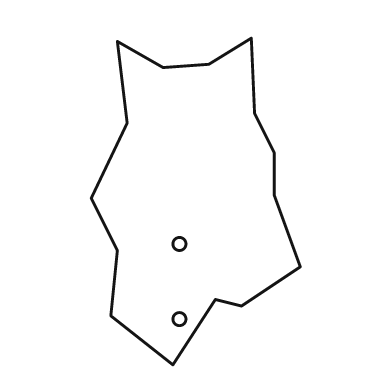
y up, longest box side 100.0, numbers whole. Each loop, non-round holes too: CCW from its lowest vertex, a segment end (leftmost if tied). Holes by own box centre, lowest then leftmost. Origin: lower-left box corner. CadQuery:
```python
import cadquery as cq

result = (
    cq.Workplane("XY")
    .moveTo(25.0, 0.0)
    .lineTo(38.0, 20.0)
    .lineTo(46.0, 18.0)
    .lineTo(64.0, 30.0)
    .lineTo(56.0, 52.0)
    .lineTo(56.0, 65.0)
    .lineTo(50.0, 77.0)
    .lineTo(49.0, 100.0)
    .lineTo(36.0, 92.0)
    .lineTo(22.0, 91.0)
    .lineTo(8.0, 99.0)
    .lineTo(11.0, 74.0)
    .lineTo(0.0, 51.0)
    .lineTo(8.0, 35.0)
    .lineTo(6.0, 15.0)
    .close()
    .moveTo(27.0, 14.0)
    .circle(2.0)
    .moveTo(27.0, 37.0)
    .circle(2.0)
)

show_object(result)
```